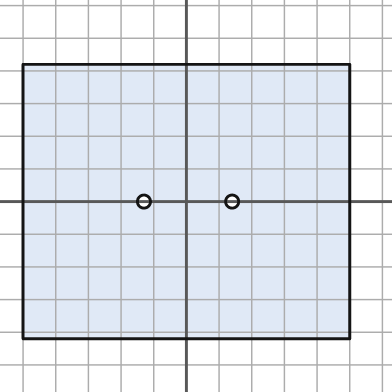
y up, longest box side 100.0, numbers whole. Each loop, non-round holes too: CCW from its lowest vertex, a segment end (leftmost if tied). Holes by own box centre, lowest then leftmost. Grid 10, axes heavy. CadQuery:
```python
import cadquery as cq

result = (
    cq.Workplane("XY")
    .moveTo(-50.0, -42.0)
    .lineTo(50.0, -42.0)
    .lineTo(50.0, 42.0)
    .lineTo(-50.0, 42.0)
    .close()
    .moveTo(-13.0, 0.0)
    .circle(2.0)
    .moveTo(14.0, 0.0)
    .circle(2.0)
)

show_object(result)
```